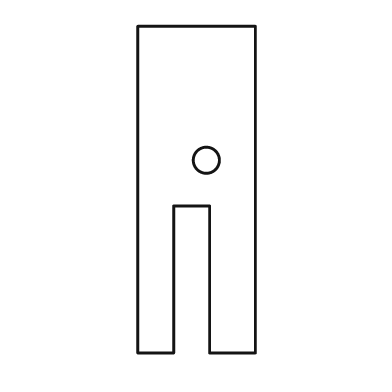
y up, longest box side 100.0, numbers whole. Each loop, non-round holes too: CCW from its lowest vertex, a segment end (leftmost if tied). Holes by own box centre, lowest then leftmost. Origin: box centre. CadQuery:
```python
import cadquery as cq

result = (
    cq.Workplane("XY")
    .moveTo(-18.0, -50.0)
    .lineTo(-7.0, -50.0)
    .lineTo(-7.0, -5.0)
    .lineTo(4.0, -5.0)
    .lineTo(4.0, -50.0)
    .lineTo(18.0, -50.0)
    .lineTo(18.0, 50.0)
    .lineTo(-18.0, 50.0)
    .close()
    .moveTo(3.0, 9.0)
    .circle(4.0)
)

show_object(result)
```